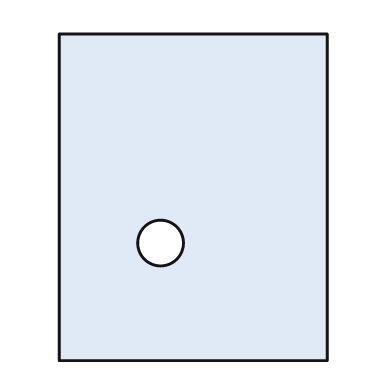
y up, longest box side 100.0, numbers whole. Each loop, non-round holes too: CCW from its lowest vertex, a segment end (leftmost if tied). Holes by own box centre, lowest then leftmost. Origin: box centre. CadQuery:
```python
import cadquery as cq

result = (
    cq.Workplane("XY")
    .moveTo(-41.0, -50.0)
    .lineTo(41.0, -50.0)
    .lineTo(41.0, 50.0)
    .lineTo(-41.0, 50.0)
    .close()
    .moveTo(-10.0, -14.0)
    .circle(7.0)
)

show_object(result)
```